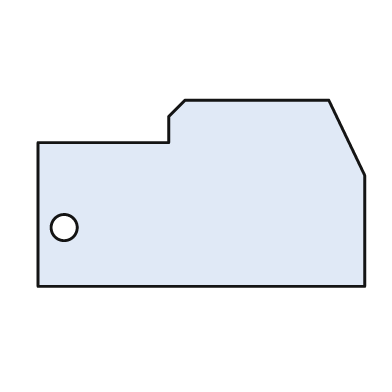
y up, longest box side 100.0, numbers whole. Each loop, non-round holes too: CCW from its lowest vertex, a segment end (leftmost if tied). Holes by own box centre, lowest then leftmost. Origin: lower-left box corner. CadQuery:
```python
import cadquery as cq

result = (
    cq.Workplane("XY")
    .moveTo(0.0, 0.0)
    .lineTo(100.0, 0.0)
    .lineTo(100.0, 34.0)
    .lineTo(89.0, 57.0)
    .lineTo(45.0, 57.0)
    .lineTo(40.0, 52.0)
    .lineTo(40.0, 44.0)
    .lineTo(0.0, 44.0)
    .close()
    .moveTo(8.0, 18.0)
    .circle(4.0)
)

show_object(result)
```